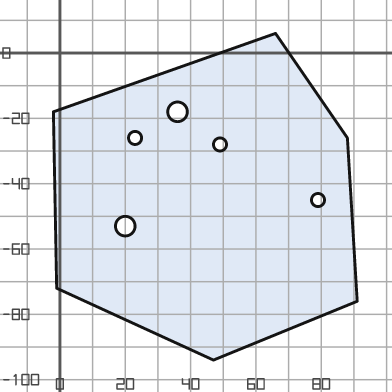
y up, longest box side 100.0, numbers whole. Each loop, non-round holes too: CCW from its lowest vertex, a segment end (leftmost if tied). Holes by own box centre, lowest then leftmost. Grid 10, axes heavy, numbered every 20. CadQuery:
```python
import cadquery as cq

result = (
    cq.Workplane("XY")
    .moveTo(47.0, -94.0)
    .lineTo(91.0, -76.0)
    .lineTo(88.0, -26.0)
    .lineTo(66.0, 6.0)
    .lineTo(-2.0, -18.0)
    .lineTo(-1.0, -72.0)
    .close()
    .moveTo(20.0, -53.0)
    .circle(3.0)
    .moveTo(79.0, -45.0)
    .circle(2.0)
    .moveTo(49.0, -28.0)
    .circle(2.0)
    .moveTo(23.0, -26.0)
    .circle(2.0)
    .moveTo(36.0, -18.0)
    .circle(3.0)
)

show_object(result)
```